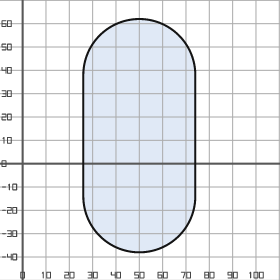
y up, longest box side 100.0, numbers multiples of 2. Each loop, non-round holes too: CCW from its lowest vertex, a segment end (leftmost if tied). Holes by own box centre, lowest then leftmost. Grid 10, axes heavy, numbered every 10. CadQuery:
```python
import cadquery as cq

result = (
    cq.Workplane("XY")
    .moveTo(26.0, -14.0)
    .threePointArc((50.0, -38.0), (74.0, -14.0))
    .lineTo(74.0, 38.0)
    .threePointArc((50.0, 62.0), (26.0, 38.0))
    .close()
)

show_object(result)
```